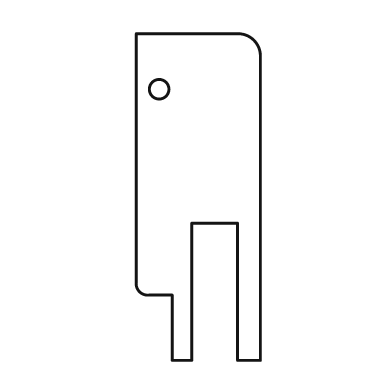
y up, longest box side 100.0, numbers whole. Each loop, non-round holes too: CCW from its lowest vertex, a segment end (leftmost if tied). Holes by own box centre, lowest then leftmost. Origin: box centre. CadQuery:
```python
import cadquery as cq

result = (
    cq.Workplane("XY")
    .moveTo(-8.0, -50.0)
    .lineTo(-2.0, -50.0)
    .lineTo(-2.0, -8.0)
    .lineTo(12.0, -8.0)
    .lineTo(12.0, -50.0)
    .lineTo(19.0, -50.0)
    .lineTo(19.0, 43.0)
    .threePointArc((17.0, 48.0), (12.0, 50.0))
    .lineTo(-19.0, 50.0)
    .lineTo(-19.0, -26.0)
    .threePointArc((-18.0, -29.0), (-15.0, -30.0))
    .lineTo(-8.0, -30.0)
    .close()
    .moveTo(-12.0, 33.0)
    .circle(3.0)
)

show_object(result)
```